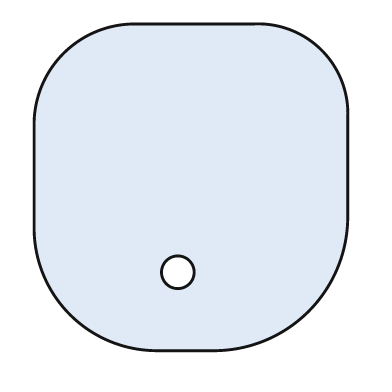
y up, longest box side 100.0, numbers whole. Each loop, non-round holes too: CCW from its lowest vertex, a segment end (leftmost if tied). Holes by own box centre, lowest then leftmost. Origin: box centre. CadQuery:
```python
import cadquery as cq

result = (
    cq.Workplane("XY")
    .moveTo(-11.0, -50.0)
    .lineTo(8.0, -50.0)
    .threePointArc((36.0, -38.0), (48.0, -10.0))
    .lineTo(48.0, 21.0)
    .threePointArc((40.0, 42.0), (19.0, 50.0))
    .lineTo(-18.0, 50.0)
    .threePointArc((-39.0, 41.0), (-48.0, 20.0))
    .lineTo(-48.0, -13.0)
    .threePointArc((-37.0, -39.0), (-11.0, -50.0))
    .close()
    .moveTo(-4.0, -26.0)
    .circle(5.0)
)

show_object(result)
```